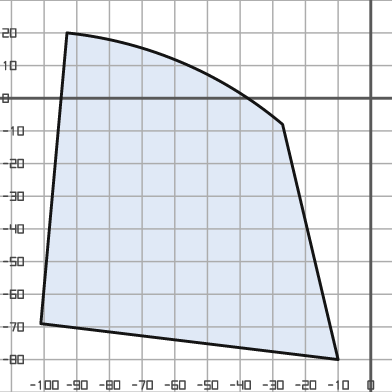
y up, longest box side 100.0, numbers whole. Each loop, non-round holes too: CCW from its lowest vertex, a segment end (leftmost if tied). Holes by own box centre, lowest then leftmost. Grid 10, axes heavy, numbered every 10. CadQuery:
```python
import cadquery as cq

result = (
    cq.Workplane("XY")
    .moveTo(-10.0, -80.0)
    .lineTo(-27.0, -8.0)
    .threePointArc((-58.0, 11.0), (-93.0, 20.0))
    .lineTo(-101.0, -69.0)
    .close()
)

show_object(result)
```